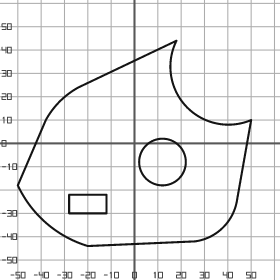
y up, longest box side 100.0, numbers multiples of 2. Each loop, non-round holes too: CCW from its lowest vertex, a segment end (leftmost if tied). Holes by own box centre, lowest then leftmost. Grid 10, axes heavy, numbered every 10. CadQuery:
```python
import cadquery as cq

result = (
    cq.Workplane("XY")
    .moveTo(-20.0, -44.0)
    .lineTo(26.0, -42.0)
    .threePointArc((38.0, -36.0), (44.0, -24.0))
    .lineTo(50.0, 10.0)
    .threePointArc((22.0, 16.0), (18.0, 44.0))
    .lineTo(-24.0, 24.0)
    .threePointArc((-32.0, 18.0), (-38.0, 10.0))
    .lineTo(-50.0, -18.0)
    .threePointArc((-38.0, -34.0), (-20.0, -44.0))
    .close()
    .moveTo(-28.0, -30.0)
    .lineTo(-12.0, -30.0)
    .lineTo(-12.0, -22.0)
    .lineTo(-28.0, -22.0)
    .close()
    .moveTo(12.0, -8.0)
    .circle(10.0)
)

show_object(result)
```